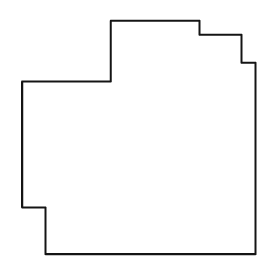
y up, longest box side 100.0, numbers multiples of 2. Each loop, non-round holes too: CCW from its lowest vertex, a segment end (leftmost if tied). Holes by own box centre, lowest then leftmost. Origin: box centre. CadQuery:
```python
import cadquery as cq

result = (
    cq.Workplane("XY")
    .moveTo(-40.0, -50.0)
    .lineTo(50.0, -50.0)
    .lineTo(50.0, 32.0)
    .lineTo(44.0, 32.0)
    .lineTo(44.0, 44.0)
    .lineTo(26.0, 44.0)
    .lineTo(26.0, 50.0)
    .lineTo(-12.0, 50.0)
    .lineTo(-12.0, 24.0)
    .lineTo(-50.0, 24.0)
    .lineTo(-50.0, -30.0)
    .lineTo(-40.0, -30.0)
    .close()
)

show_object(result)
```